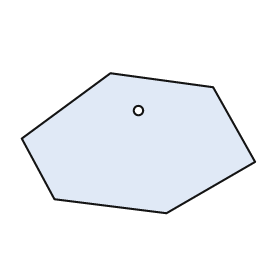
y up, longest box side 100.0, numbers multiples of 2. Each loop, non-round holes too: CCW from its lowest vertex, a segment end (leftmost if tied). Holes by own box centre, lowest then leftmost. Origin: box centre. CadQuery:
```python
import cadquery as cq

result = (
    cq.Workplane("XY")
    .moveTo(12.0, -30.0)
    .lineTo(50.0, -8.0)
    .lineTo(32.0, 24.0)
    .lineTo(-12.0, 30.0)
    .lineTo(-50.0, 2.0)
    .lineTo(-36.0, -24.0)
    .close()
    .moveTo(0.0, 14.0)
    .circle(2.0)
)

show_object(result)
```